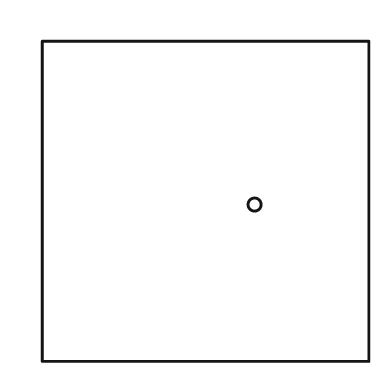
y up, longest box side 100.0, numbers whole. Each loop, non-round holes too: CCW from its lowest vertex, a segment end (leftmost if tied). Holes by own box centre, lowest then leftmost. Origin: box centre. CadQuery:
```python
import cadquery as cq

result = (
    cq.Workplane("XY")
    .moveTo(-50.0, -49.0)
    .lineTo(50.0, -49.0)
    .lineTo(50.0, 49.0)
    .lineTo(-50.0, 49.0)
    .close()
    .moveTo(15.0, -1.0)
    .circle(2.0)
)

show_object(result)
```